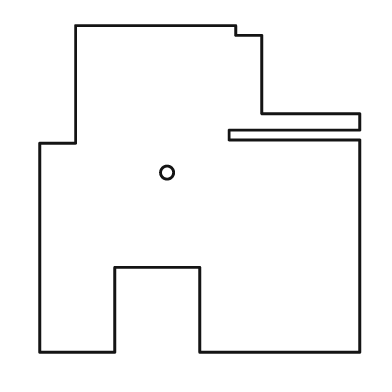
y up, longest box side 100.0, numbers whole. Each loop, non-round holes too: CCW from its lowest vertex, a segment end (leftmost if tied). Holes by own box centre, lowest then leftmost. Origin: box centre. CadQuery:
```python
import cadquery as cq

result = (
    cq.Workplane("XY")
    .moveTo(-49.0, -50.0)
    .lineTo(-26.0, -50.0)
    .lineTo(-26.0, -24.0)
    .lineTo(0.0, -24.0)
    .lineTo(0.0, -50.0)
    .lineTo(49.0, -50.0)
    .lineTo(49.0, 15.0)
    .lineTo(9.0, 15.0)
    .lineTo(9.0, 18.0)
    .lineTo(49.0, 18.0)
    .lineTo(49.0, 23.0)
    .lineTo(19.0, 23.0)
    .lineTo(19.0, 47.0)
    .lineTo(11.0, 47.0)
    .lineTo(11.0, 50.0)
    .lineTo(-38.0, 50.0)
    .lineTo(-38.0, 14.0)
    .lineTo(-49.0, 14.0)
    .close()
    .moveTo(-10.0, 5.0)
    .circle(2.0)
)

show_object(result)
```